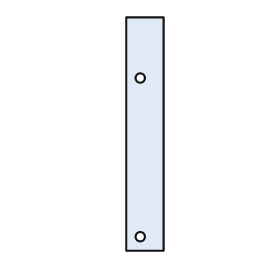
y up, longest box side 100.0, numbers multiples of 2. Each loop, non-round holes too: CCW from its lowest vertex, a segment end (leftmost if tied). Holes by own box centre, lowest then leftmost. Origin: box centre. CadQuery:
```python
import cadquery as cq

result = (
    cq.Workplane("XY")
    .moveTo(-8.0, -50.0)
    .lineTo(8.0, -50.0)
    .lineTo(8.0, 50.0)
    .lineTo(-8.0, 50.0)
    .close()
    .moveTo(-2.0, -44.0)
    .circle(2.0)
    .moveTo(-2.0, 24.0)
    .circle(2.0)
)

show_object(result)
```